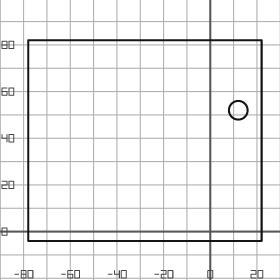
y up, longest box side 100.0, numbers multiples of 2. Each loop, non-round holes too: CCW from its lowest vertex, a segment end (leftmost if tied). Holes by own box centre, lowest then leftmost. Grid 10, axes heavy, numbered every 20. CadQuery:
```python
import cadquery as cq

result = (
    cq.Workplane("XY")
    .moveTo(-78.0, -4.0)
    .lineTo(22.0, -4.0)
    .lineTo(22.0, 82.0)
    .lineTo(-78.0, 82.0)
    .close()
    .moveTo(12.0, 52.0)
    .circle(4.0)
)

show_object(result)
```